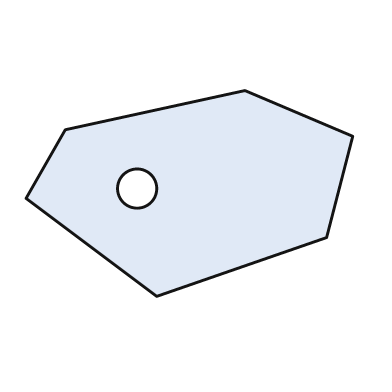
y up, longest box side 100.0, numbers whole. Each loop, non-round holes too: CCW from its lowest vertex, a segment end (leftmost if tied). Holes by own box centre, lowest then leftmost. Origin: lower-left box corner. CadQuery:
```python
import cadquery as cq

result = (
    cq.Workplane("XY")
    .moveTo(40.0, 0.0)
    .lineTo(92.0, 18.0)
    .lineTo(100.0, 49.0)
    .lineTo(67.0, 63.0)
    .lineTo(12.0, 51.0)
    .lineTo(0.0, 30.0)
    .close()
    .moveTo(34.0, 33.0)
    .circle(6.0)
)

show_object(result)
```